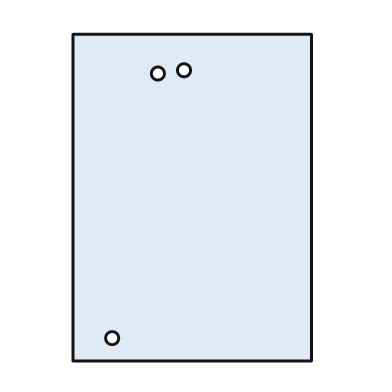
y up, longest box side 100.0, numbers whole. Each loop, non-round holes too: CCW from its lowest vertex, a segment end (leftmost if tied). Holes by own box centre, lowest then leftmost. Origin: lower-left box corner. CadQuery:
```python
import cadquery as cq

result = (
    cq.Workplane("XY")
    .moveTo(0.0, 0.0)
    .lineTo(73.0, 0.0)
    .lineTo(73.0, 100.0)
    .lineTo(0.0, 100.0)
    .close()
    .moveTo(12.0, 7.0)
    .circle(2.0)
    .moveTo(26.0, 88.0)
    .circle(2.0)
    .moveTo(34.0, 89.0)
    .circle(2.0)
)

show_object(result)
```